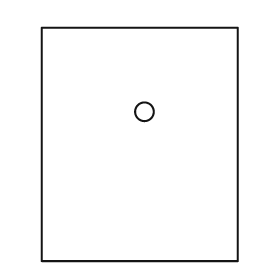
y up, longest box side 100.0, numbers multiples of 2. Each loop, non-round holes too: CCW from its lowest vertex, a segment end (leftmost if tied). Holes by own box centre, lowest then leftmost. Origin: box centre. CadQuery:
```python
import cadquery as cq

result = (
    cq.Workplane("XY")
    .moveTo(-42.0, -50.0)
    .lineTo(42.0, -50.0)
    .lineTo(42.0, 50.0)
    .lineTo(-42.0, 50.0)
    .close()
    .moveTo(2.0, 14.0)
    .circle(4.0)
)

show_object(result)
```